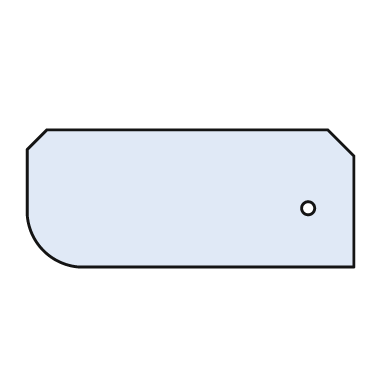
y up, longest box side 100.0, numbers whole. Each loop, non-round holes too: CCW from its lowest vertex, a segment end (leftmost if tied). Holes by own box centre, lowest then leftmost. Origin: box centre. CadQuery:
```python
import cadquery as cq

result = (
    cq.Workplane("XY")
    .moveTo(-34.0, -21.0)
    .lineTo(50.0, -21.0)
    .lineTo(50.0, 13.0)
    .lineTo(42.0, 21.0)
    .lineTo(-44.0, 21.0)
    .lineTo(-50.0, 15.0)
    .lineTo(-50.0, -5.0)
    .threePointArc((-45.0, -16.0), (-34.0, -21.0))
    .close()
    .moveTo(36.0, -3.0)
    .circle(2.0)
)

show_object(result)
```